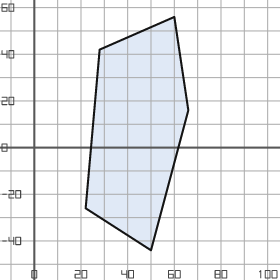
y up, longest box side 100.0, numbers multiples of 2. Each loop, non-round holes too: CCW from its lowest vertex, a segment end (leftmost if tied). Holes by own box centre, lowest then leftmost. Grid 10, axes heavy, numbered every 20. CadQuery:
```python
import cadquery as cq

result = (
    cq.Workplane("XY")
    .moveTo(50.0, -44.0)
    .lineTo(66.0, 16.0)
    .lineTo(60.0, 56.0)
    .lineTo(28.0, 42.0)
    .lineTo(22.0, -26.0)
    .close()
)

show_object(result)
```